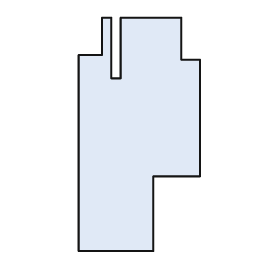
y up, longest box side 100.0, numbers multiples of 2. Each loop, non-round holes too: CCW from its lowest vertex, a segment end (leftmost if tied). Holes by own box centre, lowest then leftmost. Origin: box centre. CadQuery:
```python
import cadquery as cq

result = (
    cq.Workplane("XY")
    .moveTo(-26.0, -50.0)
    .lineTo(6.0, -50.0)
    .lineTo(6.0, -18.0)
    .lineTo(26.0, -18.0)
    .lineTo(26.0, 32.0)
    .lineTo(18.0, 32.0)
    .lineTo(18.0, 50.0)
    .lineTo(-8.0, 50.0)
    .lineTo(-8.0, 24.0)
    .lineTo(-12.0, 24.0)
    .lineTo(-12.0, 50.0)
    .lineTo(-16.0, 50.0)
    .lineTo(-16.0, 34.0)
    .lineTo(-26.0, 34.0)
    .close()
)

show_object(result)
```